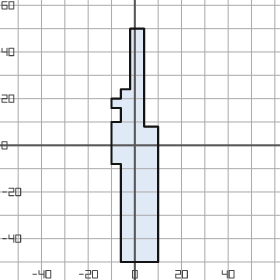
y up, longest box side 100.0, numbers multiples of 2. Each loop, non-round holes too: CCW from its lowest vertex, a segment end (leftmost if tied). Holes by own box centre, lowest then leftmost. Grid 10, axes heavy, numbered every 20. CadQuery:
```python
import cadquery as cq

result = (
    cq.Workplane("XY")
    .moveTo(-6.0, -50.0)
    .lineTo(10.0, -50.0)
    .lineTo(10.0, 8.0)
    .lineTo(4.0, 8.0)
    .lineTo(4.0, 50.0)
    .lineTo(-2.0, 50.0)
    .lineTo(-2.0, 24.0)
    .lineTo(-6.0, 24.0)
    .lineTo(-6.0, 20.0)
    .lineTo(-10.0, 20.0)
    .lineTo(-10.0, 16.0)
    .lineTo(-6.0, 16.0)
    .lineTo(-6.0, 10.0)
    .lineTo(-10.0, 10.0)
    .lineTo(-10.0, -8.0)
    .lineTo(-6.0, -8.0)
    .close()
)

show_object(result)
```